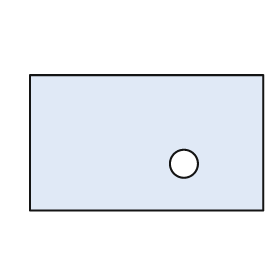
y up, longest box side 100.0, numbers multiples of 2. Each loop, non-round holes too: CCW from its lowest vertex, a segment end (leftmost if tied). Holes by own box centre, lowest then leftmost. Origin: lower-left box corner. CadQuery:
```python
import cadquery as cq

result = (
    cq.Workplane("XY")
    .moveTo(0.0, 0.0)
    .lineTo(100.0, 0.0)
    .lineTo(100.0, 58.0)
    .lineTo(0.0, 58.0)
    .close()
    .moveTo(66.0, 20.0)
    .circle(6.0)
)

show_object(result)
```